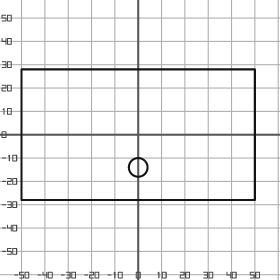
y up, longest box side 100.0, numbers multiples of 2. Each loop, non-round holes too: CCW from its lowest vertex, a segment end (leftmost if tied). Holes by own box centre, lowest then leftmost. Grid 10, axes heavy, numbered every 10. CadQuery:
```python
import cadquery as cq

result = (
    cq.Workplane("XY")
    .moveTo(-50.0, -28.0)
    .lineTo(50.0, -28.0)
    .lineTo(50.0, 28.0)
    .lineTo(-50.0, 28.0)
    .close()
    .moveTo(0.0, -14.0)
    .circle(4.0)
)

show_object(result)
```